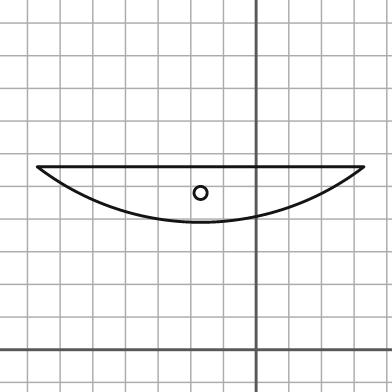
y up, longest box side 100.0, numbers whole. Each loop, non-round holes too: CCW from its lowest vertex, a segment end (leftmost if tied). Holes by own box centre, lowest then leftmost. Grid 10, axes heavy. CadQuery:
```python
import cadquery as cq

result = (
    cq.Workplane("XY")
    .moveTo(-67.0, 56.0)
    .threePointArc((-17.0, 39.0), (33.0, 56.0))
    .close()
    .moveTo(-17.0, 48.0)
    .circle(2.0)
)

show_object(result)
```